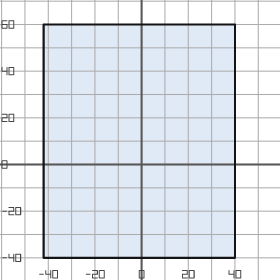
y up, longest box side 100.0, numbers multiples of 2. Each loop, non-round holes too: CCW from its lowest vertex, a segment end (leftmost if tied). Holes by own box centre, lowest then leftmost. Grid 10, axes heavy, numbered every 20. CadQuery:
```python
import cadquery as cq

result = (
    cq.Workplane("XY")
    .moveTo(-42.0, -40.0)
    .lineTo(40.0, -40.0)
    .lineTo(40.0, 60.0)
    .lineTo(-42.0, 60.0)
    .close()
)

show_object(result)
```